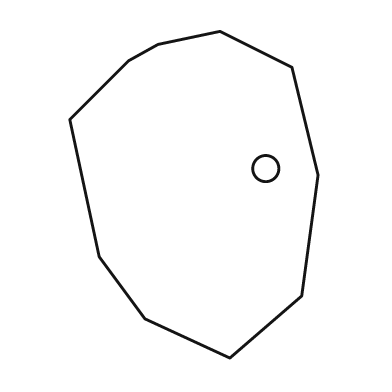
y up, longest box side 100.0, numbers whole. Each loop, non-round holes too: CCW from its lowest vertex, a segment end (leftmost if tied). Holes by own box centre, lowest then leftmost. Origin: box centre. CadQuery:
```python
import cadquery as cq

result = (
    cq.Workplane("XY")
    .moveTo(11.0, -50.0)
    .lineTo(33.0, -31.0)
    .lineTo(38.0, 6.0)
    .lineTo(30.0, 39.0)
    .lineTo(8.0, 50.0)
    .lineTo(-11.0, 46.0)
    .lineTo(-20.0, 41.0)
    .lineTo(-38.0, 23.0)
    .lineTo(-29.0, -19.0)
    .lineTo(-15.0, -38.0)
    .close()
    .moveTo(22.0, 8.0)
    .circle(4.0)
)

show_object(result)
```